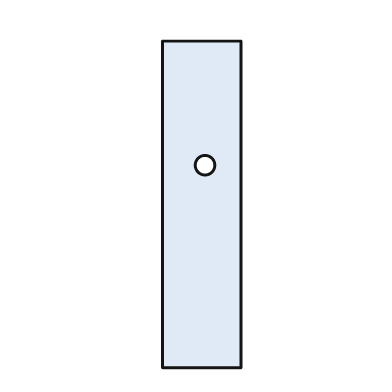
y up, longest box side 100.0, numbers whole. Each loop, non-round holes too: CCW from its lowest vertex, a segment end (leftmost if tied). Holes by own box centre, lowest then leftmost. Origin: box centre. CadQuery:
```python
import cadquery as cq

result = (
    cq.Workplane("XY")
    .moveTo(-12.0, -50.0)
    .lineTo(12.0, -50.0)
    .lineTo(12.0, 50.0)
    .lineTo(-12.0, 50.0)
    .close()
    .moveTo(1.0, 12.0)
    .circle(3.0)
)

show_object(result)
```